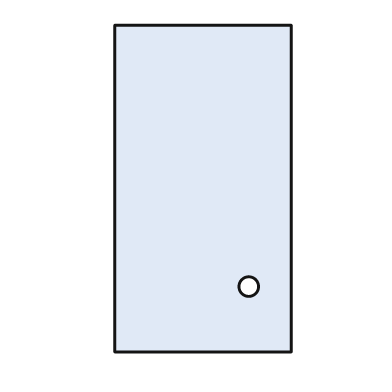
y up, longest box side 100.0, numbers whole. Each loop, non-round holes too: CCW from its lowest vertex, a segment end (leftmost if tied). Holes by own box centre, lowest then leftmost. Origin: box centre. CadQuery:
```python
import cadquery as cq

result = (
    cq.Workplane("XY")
    .moveTo(-27.0, -50.0)
    .lineTo(27.0, -50.0)
    .lineTo(27.0, 50.0)
    .lineTo(-27.0, 50.0)
    .close()
    .moveTo(14.0, -30.0)
    .circle(3.0)
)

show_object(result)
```